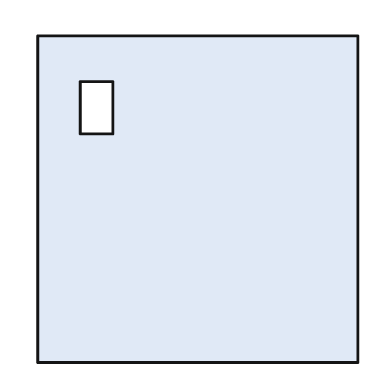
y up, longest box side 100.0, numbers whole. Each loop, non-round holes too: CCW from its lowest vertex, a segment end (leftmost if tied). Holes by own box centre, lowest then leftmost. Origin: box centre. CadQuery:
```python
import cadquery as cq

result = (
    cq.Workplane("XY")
    .moveTo(-49.0, -50.0)
    .lineTo(49.0, -50.0)
    .lineTo(49.0, 50.0)
    .lineTo(-49.0, 50.0)
    .close()
    .moveTo(-36.0, 20.0)
    .lineTo(-26.0, 20.0)
    .lineTo(-26.0, 36.0)
    .lineTo(-36.0, 36.0)
    .close()
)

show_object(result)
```